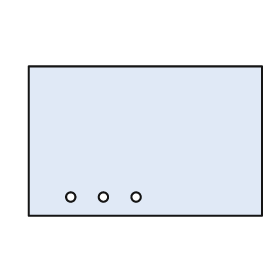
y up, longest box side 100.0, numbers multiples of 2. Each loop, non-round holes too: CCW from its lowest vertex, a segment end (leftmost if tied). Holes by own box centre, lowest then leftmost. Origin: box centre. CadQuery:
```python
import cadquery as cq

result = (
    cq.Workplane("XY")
    .moveTo(-50.0, -32.0)
    .lineTo(50.0, -32.0)
    .lineTo(50.0, 32.0)
    .lineTo(-50.0, 32.0)
    .close()
    .moveTo(-32.0, -24.0)
    .circle(2.0)
    .moveTo(-18.0, -24.0)
    .circle(2.0)
    .moveTo(-4.0, -24.0)
    .circle(2.0)
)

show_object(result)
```